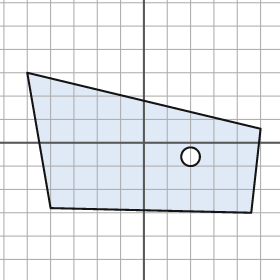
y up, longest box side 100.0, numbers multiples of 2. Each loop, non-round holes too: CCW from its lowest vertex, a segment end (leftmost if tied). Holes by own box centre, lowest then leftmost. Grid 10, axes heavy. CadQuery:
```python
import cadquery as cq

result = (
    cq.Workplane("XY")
    .moveTo(46.0, -30.0)
    .lineTo(50.0, 6.0)
    .lineTo(-50.0, 30.0)
    .lineTo(-40.0, -28.0)
    .close()
    .moveTo(20.0, -6.0)
    .circle(4.0)
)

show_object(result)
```